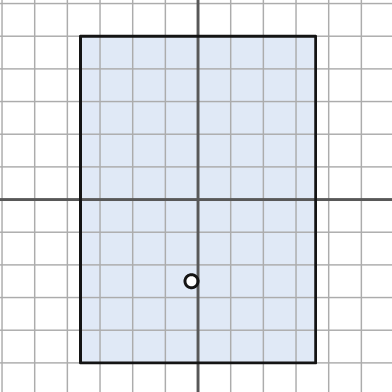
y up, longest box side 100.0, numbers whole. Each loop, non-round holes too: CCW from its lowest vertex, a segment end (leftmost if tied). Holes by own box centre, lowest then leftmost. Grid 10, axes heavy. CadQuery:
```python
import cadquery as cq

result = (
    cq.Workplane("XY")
    .moveTo(-36.0, -50.0)
    .lineTo(36.0, -50.0)
    .lineTo(36.0, 50.0)
    .lineTo(-36.0, 50.0)
    .close()
    .moveTo(-2.0, -25.0)
    .circle(2.0)
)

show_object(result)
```